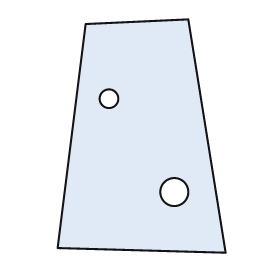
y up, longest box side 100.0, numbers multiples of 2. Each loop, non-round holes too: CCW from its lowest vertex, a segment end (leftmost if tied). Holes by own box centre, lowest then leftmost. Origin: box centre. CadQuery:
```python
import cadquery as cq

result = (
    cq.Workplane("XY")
    .moveTo(36.0, -50.0)
    .lineTo(20.0, 50.0)
    .lineTo(-24.0, 48.0)
    .lineTo(-36.0, -48.0)
    .close()
    .moveTo(14.0, -24.0)
    .circle(6.0)
    .moveTo(-14.0, 16.0)
    .circle(4.0)
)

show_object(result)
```